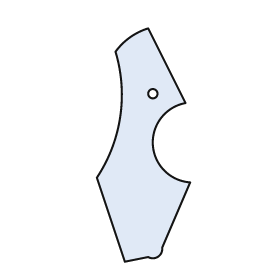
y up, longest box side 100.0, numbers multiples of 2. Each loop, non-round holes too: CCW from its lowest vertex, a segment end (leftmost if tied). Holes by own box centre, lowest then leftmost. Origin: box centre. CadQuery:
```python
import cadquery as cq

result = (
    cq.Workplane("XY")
    .moveTo(-8.0, -50.0)
    .lineTo(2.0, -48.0)
    .threePointArc((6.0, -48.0), (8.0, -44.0))
    .lineTo(20.0, -16.0)
    .threePointArc((4.0, 0.0), (18.0, 18.0))
    .lineTo(2.0, 50.0)
    .threePointArc((-6.0, 46.0), (-12.0, 40.0))
    .threePointArc((-10.0, 12.0), (-20.0, -14.0))
    .close()
    .moveTo(4.0, 22.0)
    .circle(2.0)
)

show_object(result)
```